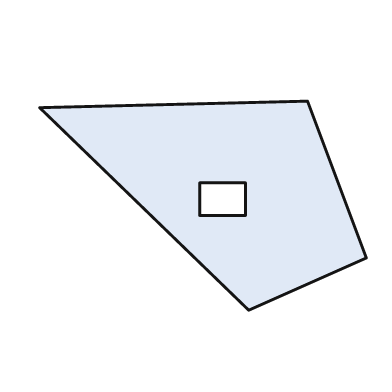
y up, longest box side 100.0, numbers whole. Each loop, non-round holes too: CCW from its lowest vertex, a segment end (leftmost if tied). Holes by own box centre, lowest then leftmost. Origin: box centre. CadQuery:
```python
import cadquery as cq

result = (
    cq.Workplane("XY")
    .moveTo(14.0, -32.0)
    .lineTo(50.0, -16.0)
    .lineTo(32.0, 32.0)
    .lineTo(-50.0, 30.0)
    .close()
    .moveTo(-1.0, -3.0)
    .lineTo(13.0, -3.0)
    .lineTo(13.0, 7.0)
    .lineTo(-1.0, 7.0)
    .close()
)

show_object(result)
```